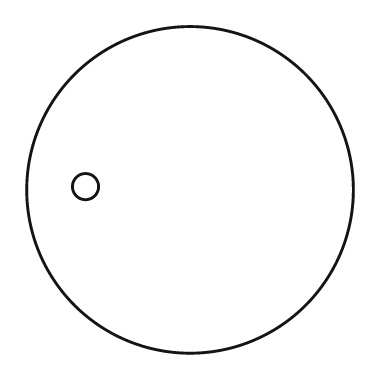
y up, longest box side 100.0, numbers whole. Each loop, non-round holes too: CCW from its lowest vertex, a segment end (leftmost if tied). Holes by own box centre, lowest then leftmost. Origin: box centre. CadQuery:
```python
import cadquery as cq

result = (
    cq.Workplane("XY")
    .moveTo(0.0, 0.0)
    .circle(50.0)
    .moveTo(-32.0, 1.0)
    .circle(4.0)
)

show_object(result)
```